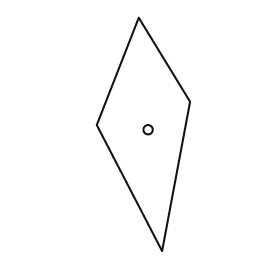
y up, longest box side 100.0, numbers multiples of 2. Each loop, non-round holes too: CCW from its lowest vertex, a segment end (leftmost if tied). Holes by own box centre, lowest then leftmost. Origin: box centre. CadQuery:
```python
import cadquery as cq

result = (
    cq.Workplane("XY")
    .moveTo(8.0, -50.0)
    .lineTo(20.0, 14.0)
    .lineTo(-2.0, 50.0)
    .lineTo(-20.0, 4.0)
    .close()
    .moveTo(2.0, 2.0)
    .circle(2.0)
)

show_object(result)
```